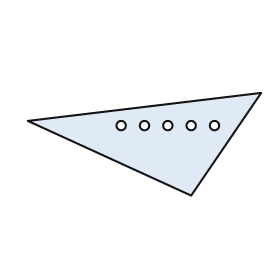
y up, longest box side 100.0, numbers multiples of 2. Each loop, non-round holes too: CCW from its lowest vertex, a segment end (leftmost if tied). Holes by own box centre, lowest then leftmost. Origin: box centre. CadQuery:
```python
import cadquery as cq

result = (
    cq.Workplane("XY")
    .moveTo(20.0, -22.0)
    .lineTo(50.0, 22.0)
    .lineTo(-50.0, 10.0)
    .close()
    .moveTo(-10.0, 8.0)
    .circle(2.0)
    .moveTo(0.0, 8.0)
    .circle(2.0)
    .moveTo(10.0, 8.0)
    .circle(2.0)
    .moveTo(20.0, 8.0)
    .circle(2.0)
    .moveTo(30.0, 8.0)
    .circle(2.0)
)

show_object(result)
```